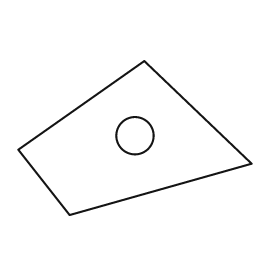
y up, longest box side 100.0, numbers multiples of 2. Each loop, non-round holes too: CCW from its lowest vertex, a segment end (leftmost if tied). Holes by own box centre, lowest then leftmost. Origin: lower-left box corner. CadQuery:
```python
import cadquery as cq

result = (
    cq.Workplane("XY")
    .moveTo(22.0, 0.0)
    .lineTo(100.0, 22.0)
    .lineTo(54.0, 66.0)
    .lineTo(0.0, 28.0)
    .close()
    .moveTo(50.0, 34.0)
    .circle(8.0)
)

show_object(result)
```